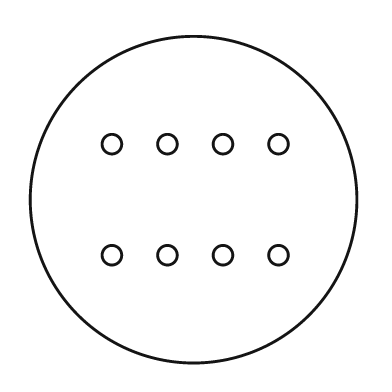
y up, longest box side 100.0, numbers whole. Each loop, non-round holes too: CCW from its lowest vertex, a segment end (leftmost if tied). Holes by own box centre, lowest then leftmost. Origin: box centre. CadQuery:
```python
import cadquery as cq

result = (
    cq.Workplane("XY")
    .moveTo(0.0, 0.0)
    .circle(50.0)
    .moveTo(-25.0, -17.0)
    .circle(3.0)
    .moveTo(-8.0, -17.0)
    .circle(3.0)
    .moveTo(9.0, -17.0)
    .circle(3.0)
    .moveTo(26.0, -17.0)
    .circle(3.0)
    .moveTo(-25.0, 17.0)
    .circle(3.0)
    .moveTo(-8.0, 17.0)
    .circle(3.0)
    .moveTo(9.0, 17.0)
    .circle(3.0)
    .moveTo(26.0, 17.0)
    .circle(3.0)
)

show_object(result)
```